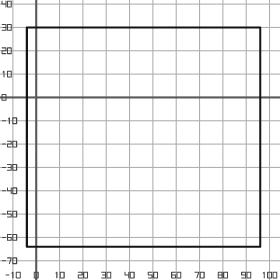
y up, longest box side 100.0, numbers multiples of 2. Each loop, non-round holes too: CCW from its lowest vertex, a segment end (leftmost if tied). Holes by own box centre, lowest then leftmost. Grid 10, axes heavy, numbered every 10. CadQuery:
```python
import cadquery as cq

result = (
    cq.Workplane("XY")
    .moveTo(-4.0, -64.0)
    .lineTo(96.0, -64.0)
    .lineTo(96.0, 30.0)
    .lineTo(-4.0, 30.0)
    .close()
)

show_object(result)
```